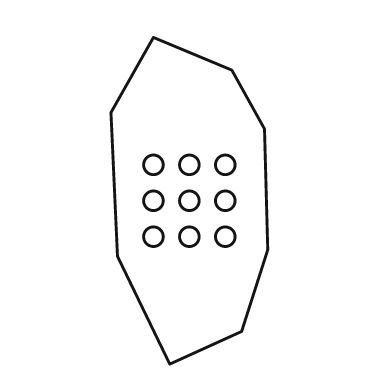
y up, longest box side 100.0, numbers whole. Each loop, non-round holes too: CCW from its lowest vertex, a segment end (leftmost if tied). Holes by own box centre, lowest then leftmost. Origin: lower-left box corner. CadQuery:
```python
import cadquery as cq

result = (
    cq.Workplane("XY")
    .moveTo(18.0, 0.0)
    .lineTo(40.0, 10.0)
    .lineTo(48.0, 35.0)
    .lineTo(47.0, 72.0)
    .lineTo(37.0, 90.0)
    .lineTo(13.0, 100.0)
    .lineTo(0.0, 77.0)
    .lineTo(2.0, 33.0)
    .close()
    .moveTo(13.0, 39.0)
    .circle(3.0)
    .moveTo(24.0, 39.0)
    .circle(3.0)
    .moveTo(35.0, 39.0)
    .circle(3.0)
    .moveTo(13.0, 50.0)
    .circle(3.0)
    .moveTo(24.0, 50.0)
    .circle(3.0)
    .moveTo(35.0, 50.0)
    .circle(3.0)
    .moveTo(13.0, 61.0)
    .circle(3.0)
    .moveTo(24.0, 61.0)
    .circle(3.0)
    .moveTo(35.0, 61.0)
    .circle(3.0)
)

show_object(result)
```